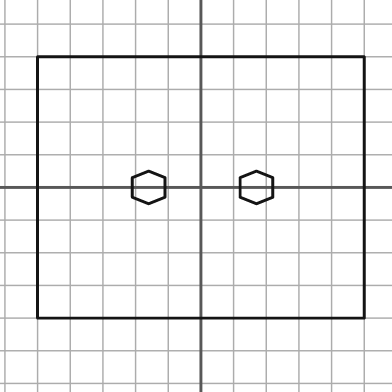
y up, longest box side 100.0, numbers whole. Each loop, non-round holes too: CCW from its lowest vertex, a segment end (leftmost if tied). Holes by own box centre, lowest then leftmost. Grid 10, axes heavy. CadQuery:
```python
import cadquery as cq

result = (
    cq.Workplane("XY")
    .moveTo(-50.0, -40.0)
    .lineTo(50.0, -40.0)
    .lineTo(50.0, 40.0)
    .lineTo(-50.0, 40.0)
    .close()
    .moveTo(-16.0, -5.0)
    .lineTo(-11.0, -3.0)
    .lineTo(-11.0, 3.0)
    .lineTo(-16.0, 5.0)
    .lineTo(-21.0, 3.0)
    .lineTo(-21.0, -3.0)
    .close()
    .moveTo(17.0, -5.0)
    .lineTo(22.0, -3.0)
    .lineTo(22.0, 3.0)
    .lineTo(17.0, 5.0)
    .lineTo(12.0, 3.0)
    .lineTo(12.0, -3.0)
    .close()
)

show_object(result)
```